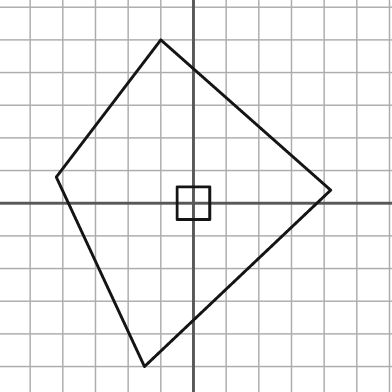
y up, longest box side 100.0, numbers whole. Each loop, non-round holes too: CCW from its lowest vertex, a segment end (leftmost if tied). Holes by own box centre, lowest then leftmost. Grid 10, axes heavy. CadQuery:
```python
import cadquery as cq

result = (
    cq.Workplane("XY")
    .moveTo(-15.0, -50.0)
    .lineTo(42.0, 4.0)
    .lineTo(-10.0, 50.0)
    .lineTo(-42.0, 8.0)
    .close()
    .moveTo(-5.0, -5.0)
    .lineTo(5.0, -5.0)
    .lineTo(5.0, 5.0)
    .lineTo(-5.0, 5.0)
    .close()
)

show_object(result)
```